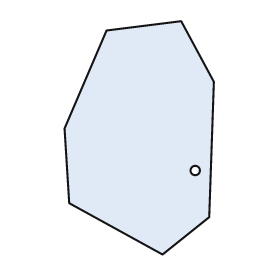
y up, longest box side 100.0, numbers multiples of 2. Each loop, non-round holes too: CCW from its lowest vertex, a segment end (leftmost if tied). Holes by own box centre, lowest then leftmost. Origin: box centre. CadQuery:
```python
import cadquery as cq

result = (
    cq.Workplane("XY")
    .moveTo(10.0, -50.0)
    .lineTo(30.0, -34.0)
    .lineTo(32.0, 24.0)
    .lineTo(18.0, 50.0)
    .lineTo(-14.0, 46.0)
    .lineTo(-32.0, 4.0)
    .lineTo(-30.0, -28.0)
    .close()
    .moveTo(24.0, -14.0)
    .circle(2.0)
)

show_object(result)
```